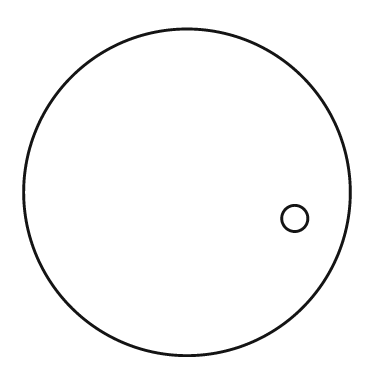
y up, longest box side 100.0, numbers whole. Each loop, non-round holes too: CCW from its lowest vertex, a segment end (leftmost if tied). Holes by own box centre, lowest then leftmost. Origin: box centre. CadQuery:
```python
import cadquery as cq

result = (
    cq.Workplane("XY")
    .moveTo(0.0, 0.0)
    .circle(50.0)
    .moveTo(33.0, -8.0)
    .circle(4.0)
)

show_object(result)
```